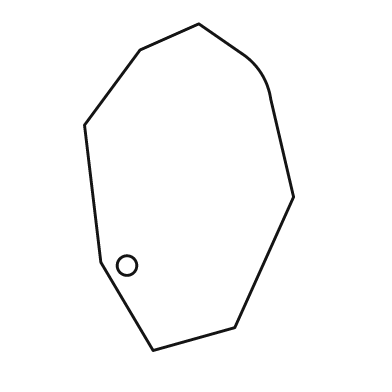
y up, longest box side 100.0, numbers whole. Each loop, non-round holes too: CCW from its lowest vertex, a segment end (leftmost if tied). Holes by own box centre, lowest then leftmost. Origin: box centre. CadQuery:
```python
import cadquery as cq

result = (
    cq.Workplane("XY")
    .moveTo(-11.0, -50.0)
    .lineTo(14.0, -43.0)
    .lineTo(32.0, -3.0)
    .lineTo(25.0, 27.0)
    .threePointArc((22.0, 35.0), (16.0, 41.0))
    .lineTo(3.0, 50.0)
    .lineTo(-15.0, 42.0)
    .lineTo(-32.0, 19.0)
    .lineTo(-27.0, -23.0)
    .close()
    .moveTo(-19.0, -24.0)
    .circle(3.0)
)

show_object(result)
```